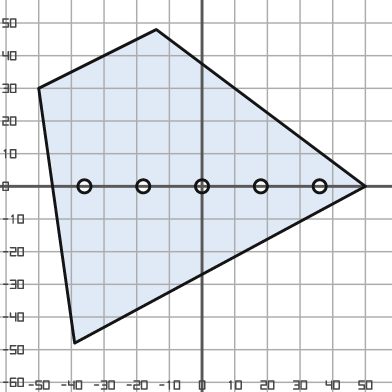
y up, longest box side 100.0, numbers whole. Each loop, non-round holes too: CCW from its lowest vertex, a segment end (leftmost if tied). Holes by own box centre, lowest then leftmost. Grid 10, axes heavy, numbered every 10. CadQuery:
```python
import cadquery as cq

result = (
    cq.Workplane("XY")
    .moveTo(-39.0, -48.0)
    .lineTo(50.0, 0.0)
    .lineTo(-14.0, 48.0)
    .lineTo(-50.0, 30.0)
    .close()
    .moveTo(-36.0, 0.0)
    .circle(2.0)
    .moveTo(-18.0, 0.0)
    .circle(2.0)
    .moveTo(0.0, 0.0)
    .circle(2.0)
    .moveTo(18.0, 0.0)
    .circle(2.0)
    .moveTo(36.0, 0.0)
    .circle(2.0)
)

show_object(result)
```